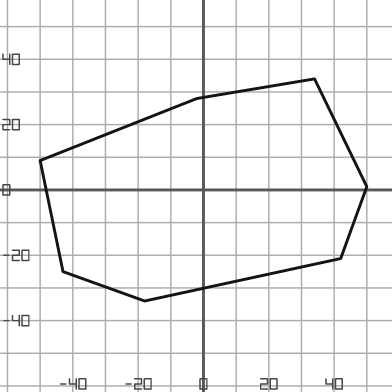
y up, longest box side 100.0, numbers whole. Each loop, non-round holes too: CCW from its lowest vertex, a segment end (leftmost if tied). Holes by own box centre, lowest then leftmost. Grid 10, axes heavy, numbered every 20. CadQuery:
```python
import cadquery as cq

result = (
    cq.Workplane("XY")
    .moveTo(-18.0, -34.0)
    .lineTo(42.0, -21.0)
    .lineTo(50.0, 1.0)
    .lineTo(34.0, 34.0)
    .lineTo(-2.0, 28.0)
    .lineTo(-50.0, 9.0)
    .lineTo(-43.0, -25.0)
    .close()
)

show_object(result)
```